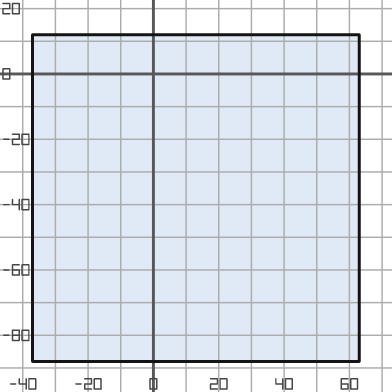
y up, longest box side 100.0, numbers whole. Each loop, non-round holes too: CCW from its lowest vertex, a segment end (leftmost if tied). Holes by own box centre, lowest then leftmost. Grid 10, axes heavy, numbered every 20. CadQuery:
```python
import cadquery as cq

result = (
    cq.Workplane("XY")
    .moveTo(-37.0, -88.0)
    .lineTo(63.0, -88.0)
    .lineTo(63.0, 12.0)
    .lineTo(-37.0, 12.0)
    .close()
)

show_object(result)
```